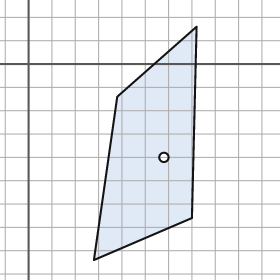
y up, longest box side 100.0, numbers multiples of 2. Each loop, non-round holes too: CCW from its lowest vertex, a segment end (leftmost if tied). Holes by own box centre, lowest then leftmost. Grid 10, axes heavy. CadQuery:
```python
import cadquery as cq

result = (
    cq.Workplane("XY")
    .moveTo(28.0, -84.0)
    .lineTo(70.0, -66.0)
    .lineTo(72.0, 16.0)
    .lineTo(38.0, -14.0)
    .close()
    .moveTo(58.0, -40.0)
    .circle(2.0)
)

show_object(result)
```